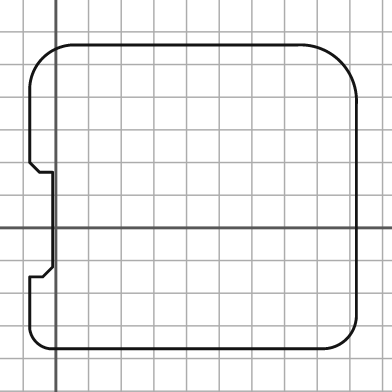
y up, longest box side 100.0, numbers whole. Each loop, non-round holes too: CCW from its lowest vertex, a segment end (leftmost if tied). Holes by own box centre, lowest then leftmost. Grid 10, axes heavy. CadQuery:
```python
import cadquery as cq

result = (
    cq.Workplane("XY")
    .moveTo(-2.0, -37.0)
    .lineTo(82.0, -37.0)
    .threePointArc((89.0, -34.0), (92.0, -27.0))
    .lineTo(92.0, 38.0)
    .threePointArc((87.0, 51.0), (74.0, 56.0))
    .lineTo(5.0, 56.0)
    .threePointArc((-4.0, 52.0), (-8.0, 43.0))
    .lineTo(-8.0, 20.0)
    .lineTo(-5.0, 17.0)
    .lineTo(-1.0, 17.0)
    .lineTo(-1.0, -12.0)
    .lineTo(-4.0, -15.0)
    .lineTo(-8.0, -15.0)
    .lineTo(-8.0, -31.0)
    .threePointArc((-6.0, -35.0), (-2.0, -37.0))
    .close()
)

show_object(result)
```